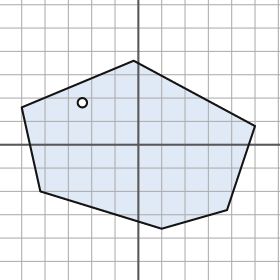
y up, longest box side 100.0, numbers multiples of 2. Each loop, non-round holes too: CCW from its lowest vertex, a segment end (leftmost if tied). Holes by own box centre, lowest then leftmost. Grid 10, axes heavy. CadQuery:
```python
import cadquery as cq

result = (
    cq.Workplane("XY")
    .moveTo(10.0, -36.0)
    .lineTo(38.0, -28.0)
    .lineTo(50.0, 8.0)
    .lineTo(-2.0, 36.0)
    .lineTo(-50.0, 16.0)
    .lineTo(-42.0, -20.0)
    .close()
    .moveTo(-24.0, 18.0)
    .circle(2.0)
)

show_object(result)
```